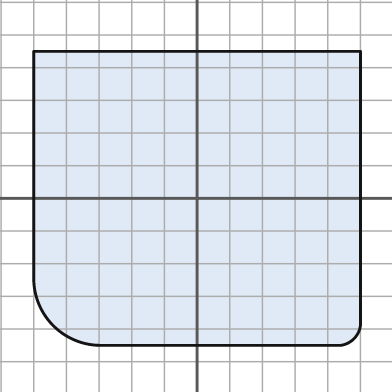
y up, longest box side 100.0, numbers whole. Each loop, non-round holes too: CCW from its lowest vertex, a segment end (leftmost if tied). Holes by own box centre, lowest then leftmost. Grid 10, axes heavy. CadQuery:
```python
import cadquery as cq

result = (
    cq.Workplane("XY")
    .moveTo(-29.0, -45.0)
    .lineTo(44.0, -45.0)
    .threePointArc((48.0, -43.0), (50.0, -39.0))
    .lineTo(50.0, 45.0)
    .lineTo(-50.0, 45.0)
    .lineTo(-50.0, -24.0)
    .threePointArc((-44.0, -39.0), (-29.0, -45.0))
    .close()
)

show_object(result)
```